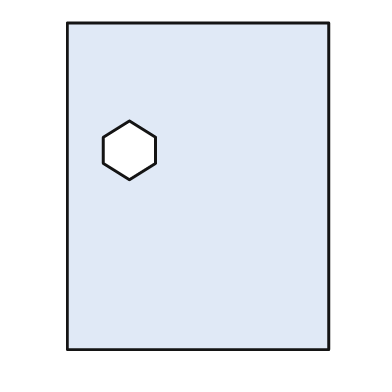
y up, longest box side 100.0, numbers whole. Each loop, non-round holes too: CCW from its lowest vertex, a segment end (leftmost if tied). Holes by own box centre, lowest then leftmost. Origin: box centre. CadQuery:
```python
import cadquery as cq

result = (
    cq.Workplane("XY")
    .moveTo(-40.0, -50.0)
    .lineTo(40.0, -50.0)
    .lineTo(40.0, 50.0)
    .lineTo(-40.0, 50.0)
    .close()
    .moveTo(-21.0, 2.0)
    .lineTo(-13.0, 7.0)
    .lineTo(-13.0, 15.0)
    .lineTo(-21.0, 20.0)
    .lineTo(-29.0, 15.0)
    .lineTo(-29.0, 7.0)
    .close()
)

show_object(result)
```